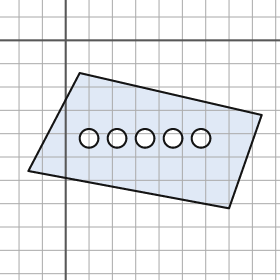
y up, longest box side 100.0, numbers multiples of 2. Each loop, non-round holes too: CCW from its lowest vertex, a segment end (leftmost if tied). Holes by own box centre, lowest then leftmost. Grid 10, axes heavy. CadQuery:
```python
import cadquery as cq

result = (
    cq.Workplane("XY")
    .moveTo(70.0, -72.0)
    .lineTo(84.0, -32.0)
    .lineTo(6.0, -14.0)
    .lineTo(-16.0, -56.0)
    .close()
    .moveTo(10.0, -42.0)
    .circle(4.0)
    .moveTo(22.0, -42.0)
    .circle(4.0)
    .moveTo(34.0, -42.0)
    .circle(4.0)
    .moveTo(46.0, -42.0)
    .circle(4.0)
    .moveTo(58.0, -42.0)
    .circle(4.0)
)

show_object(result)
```